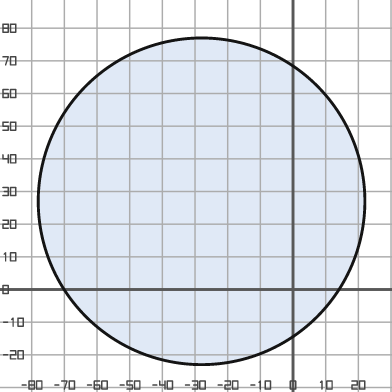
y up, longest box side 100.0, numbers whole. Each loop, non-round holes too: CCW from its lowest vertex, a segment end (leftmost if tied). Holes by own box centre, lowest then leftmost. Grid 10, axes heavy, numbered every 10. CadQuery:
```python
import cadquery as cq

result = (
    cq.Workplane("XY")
    .moveTo(-28.0, 27.0)
    .circle(50.0)
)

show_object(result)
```